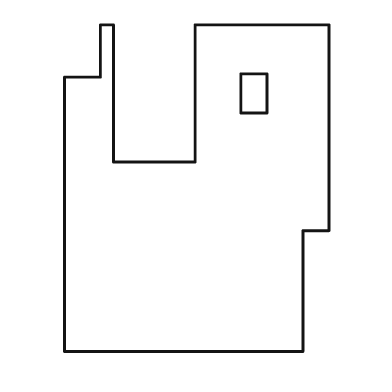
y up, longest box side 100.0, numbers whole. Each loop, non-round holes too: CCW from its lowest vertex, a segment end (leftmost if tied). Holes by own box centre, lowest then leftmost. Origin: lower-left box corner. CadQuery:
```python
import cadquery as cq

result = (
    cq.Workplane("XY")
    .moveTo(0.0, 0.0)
    .lineTo(73.0, 0.0)
    .lineTo(73.0, 37.0)
    .lineTo(81.0, 37.0)
    .lineTo(81.0, 100.0)
    .lineTo(40.0, 100.0)
    .lineTo(40.0, 58.0)
    .lineTo(15.0, 58.0)
    .lineTo(15.0, 100.0)
    .lineTo(11.0, 100.0)
    .lineTo(11.0, 84.0)
    .lineTo(0.0, 84.0)
    .close()
    .moveTo(54.0, 73.0)
    .lineTo(62.0, 73.0)
    .lineTo(62.0, 85.0)
    .lineTo(54.0, 85.0)
    .close()
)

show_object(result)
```